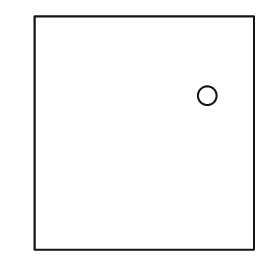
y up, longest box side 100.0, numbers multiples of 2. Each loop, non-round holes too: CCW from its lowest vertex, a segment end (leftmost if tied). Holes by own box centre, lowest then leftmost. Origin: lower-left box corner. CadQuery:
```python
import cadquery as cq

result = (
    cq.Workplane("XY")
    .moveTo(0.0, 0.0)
    .lineTo(94.0, 0.0)
    .lineTo(94.0, 100.0)
    .lineTo(0.0, 100.0)
    .close()
    .moveTo(74.0, 66.0)
    .circle(4.0)
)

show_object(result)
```